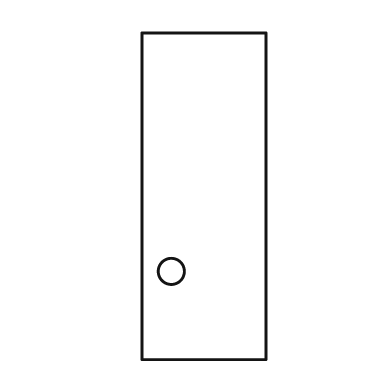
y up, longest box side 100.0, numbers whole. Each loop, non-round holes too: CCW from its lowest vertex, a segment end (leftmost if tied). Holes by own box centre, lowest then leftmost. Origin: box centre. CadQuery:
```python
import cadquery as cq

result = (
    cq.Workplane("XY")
    .moveTo(-19.0, -50.0)
    .lineTo(19.0, -50.0)
    .lineTo(19.0, 50.0)
    .lineTo(-19.0, 50.0)
    .close()
    .moveTo(-10.0, -23.0)
    .circle(4.0)
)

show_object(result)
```